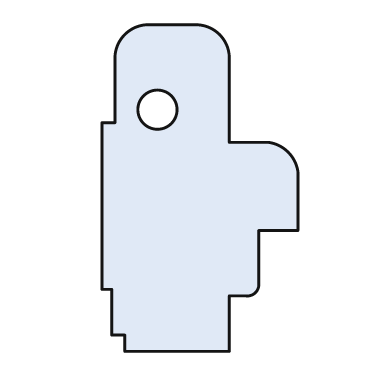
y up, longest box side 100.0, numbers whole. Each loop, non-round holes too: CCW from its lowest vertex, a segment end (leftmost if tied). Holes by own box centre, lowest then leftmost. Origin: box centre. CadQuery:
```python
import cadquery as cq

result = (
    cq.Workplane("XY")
    .moveTo(-23.0, -50.0)
    .lineTo(9.0, -50.0)
    .lineTo(9.0, -33.0)
    .lineTo(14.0, -33.0)
    .threePointArc((17.0, -32.0), (18.0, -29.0))
    .lineTo(18.0, -13.0)
    .lineTo(30.0, -13.0)
    .lineTo(30.0, 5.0)
    .threePointArc((27.0, 11.0), (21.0, 14.0))
    .lineTo(9.0, 14.0)
    .lineTo(9.0, 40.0)
    .threePointArc((6.0, 47.0), (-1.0, 50.0))
    .lineTo(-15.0, 50.0)
    .threePointArc((-23.0, 47.0), (-26.0, 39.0))
    .lineTo(-26.0, 20.0)
    .lineTo(-30.0, 20.0)
    .lineTo(-30.0, -31.0)
    .lineTo(-27.0, -31.0)
    .lineTo(-27.0, -45.0)
    .lineTo(-23.0, -45.0)
    .close()
    .moveTo(-13.0, 24.0)
    .circle(6.0)
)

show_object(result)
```